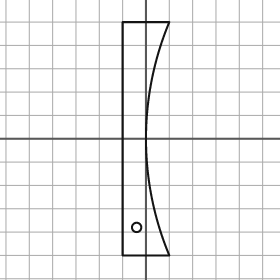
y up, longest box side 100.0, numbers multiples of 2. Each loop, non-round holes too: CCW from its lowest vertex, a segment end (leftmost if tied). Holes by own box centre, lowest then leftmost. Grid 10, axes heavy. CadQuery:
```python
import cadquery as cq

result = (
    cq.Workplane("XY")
    .moveTo(-10.0, -50.0)
    .lineTo(10.0, -50.0)
    .threePointArc((0.0, 0.0), (10.0, 50.0))
    .lineTo(-10.0, 50.0)
    .close()
    .moveTo(-4.0, -38.0)
    .circle(2.0)
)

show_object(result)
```